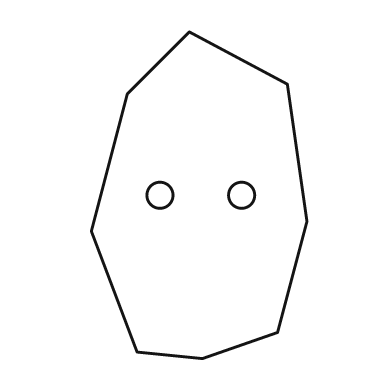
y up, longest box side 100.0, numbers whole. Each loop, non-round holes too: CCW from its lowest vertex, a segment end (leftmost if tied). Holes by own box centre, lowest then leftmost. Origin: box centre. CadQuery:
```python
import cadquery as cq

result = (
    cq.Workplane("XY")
    .moveTo(1.0, -50.0)
    .lineTo(24.0, -42.0)
    .lineTo(33.0, -8.0)
    .lineTo(27.0, 34.0)
    .lineTo(-3.0, 50.0)
    .lineTo(-22.0, 31.0)
    .lineTo(-33.0, -11.0)
    .lineTo(-19.0, -48.0)
    .close()
    .moveTo(-12.0, 0.0)
    .circle(4.0)
    .moveTo(13.0, 0.0)
    .circle(4.0)
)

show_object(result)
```